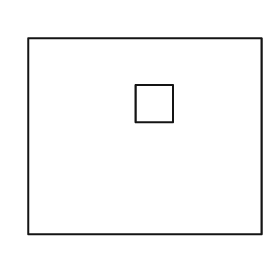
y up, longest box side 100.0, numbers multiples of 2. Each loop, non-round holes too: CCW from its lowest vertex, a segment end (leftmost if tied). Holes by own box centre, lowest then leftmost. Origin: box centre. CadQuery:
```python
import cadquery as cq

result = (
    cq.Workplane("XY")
    .moveTo(-50.0, -42.0)
    .lineTo(50.0, -42.0)
    .lineTo(50.0, 42.0)
    .lineTo(-50.0, 42.0)
    .close()
    .moveTo(-4.0, 6.0)
    .lineTo(12.0, 6.0)
    .lineTo(12.0, 22.0)
    .lineTo(-4.0, 22.0)
    .close()
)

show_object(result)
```